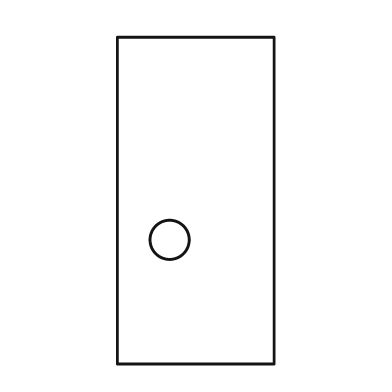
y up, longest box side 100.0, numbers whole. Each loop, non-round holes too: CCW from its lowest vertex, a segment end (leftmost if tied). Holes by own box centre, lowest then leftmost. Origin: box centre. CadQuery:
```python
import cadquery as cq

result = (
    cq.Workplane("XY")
    .moveTo(-24.0, -50.0)
    .lineTo(24.0, -50.0)
    .lineTo(24.0, 50.0)
    .lineTo(-24.0, 50.0)
    .close()
    .moveTo(-8.0, -12.0)
    .circle(6.0)
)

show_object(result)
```